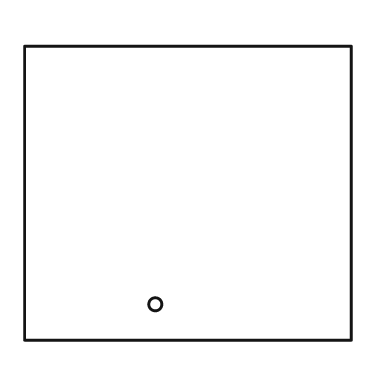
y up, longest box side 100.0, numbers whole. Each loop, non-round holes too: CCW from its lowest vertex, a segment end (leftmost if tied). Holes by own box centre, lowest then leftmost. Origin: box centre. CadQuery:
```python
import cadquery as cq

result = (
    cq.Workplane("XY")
    .moveTo(-50.0, -45.0)
    .lineTo(50.0, -45.0)
    .lineTo(50.0, 45.0)
    .lineTo(-50.0, 45.0)
    .close()
    .moveTo(-10.0, -34.0)
    .circle(2.0)
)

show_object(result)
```